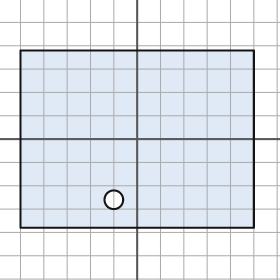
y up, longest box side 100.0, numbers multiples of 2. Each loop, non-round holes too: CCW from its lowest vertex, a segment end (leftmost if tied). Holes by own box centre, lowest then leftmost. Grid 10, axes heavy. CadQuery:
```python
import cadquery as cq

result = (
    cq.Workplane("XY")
    .moveTo(-50.0, -38.0)
    .lineTo(50.0, -38.0)
    .lineTo(50.0, 38.0)
    .lineTo(-50.0, 38.0)
    .close()
    .moveTo(-10.0, -26.0)
    .circle(4.0)
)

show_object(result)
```